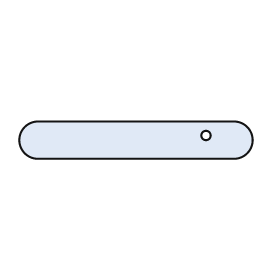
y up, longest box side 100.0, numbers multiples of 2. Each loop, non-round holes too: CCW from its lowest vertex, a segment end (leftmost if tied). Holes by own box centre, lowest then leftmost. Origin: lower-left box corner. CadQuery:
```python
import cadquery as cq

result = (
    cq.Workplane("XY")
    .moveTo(8.0, 0.0)
    .lineTo(92.0, 0.0)
    .threePointArc((100.0, 8.0), (92.0, 16.0))
    .lineTo(8.0, 16.0)
    .threePointArc((0.0, 8.0), (8.0, 0.0))
    .close()
    .moveTo(80.0, 10.0)
    .circle(2.0)
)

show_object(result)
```